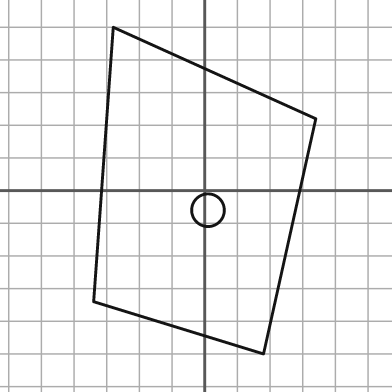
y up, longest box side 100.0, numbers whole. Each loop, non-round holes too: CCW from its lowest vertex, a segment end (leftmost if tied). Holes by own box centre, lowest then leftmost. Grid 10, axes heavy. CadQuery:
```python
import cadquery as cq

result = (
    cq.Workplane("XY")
    .moveTo(18.0, -50.0)
    .lineTo(34.0, 22.0)
    .lineTo(-28.0, 50.0)
    .lineTo(-34.0, -34.0)
    .close()
    .moveTo(1.0, -6.0)
    .circle(5.0)
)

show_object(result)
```